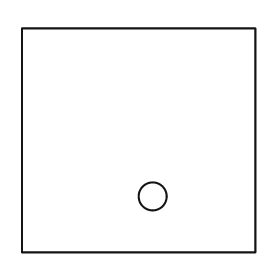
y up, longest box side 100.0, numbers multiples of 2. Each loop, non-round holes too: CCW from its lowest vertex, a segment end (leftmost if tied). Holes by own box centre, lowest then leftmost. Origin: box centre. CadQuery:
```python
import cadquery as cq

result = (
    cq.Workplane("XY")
    .moveTo(-50.0, -48.0)
    .lineTo(50.0, -48.0)
    .lineTo(50.0, 48.0)
    .lineTo(-50.0, 48.0)
    .close()
    .moveTo(6.0, -24.0)
    .circle(6.0)
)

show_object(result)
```